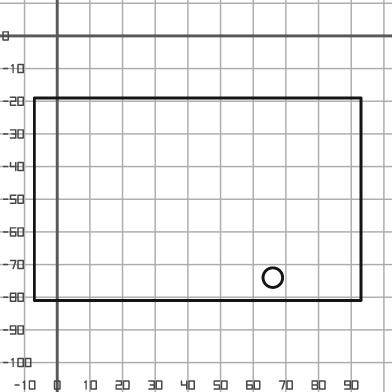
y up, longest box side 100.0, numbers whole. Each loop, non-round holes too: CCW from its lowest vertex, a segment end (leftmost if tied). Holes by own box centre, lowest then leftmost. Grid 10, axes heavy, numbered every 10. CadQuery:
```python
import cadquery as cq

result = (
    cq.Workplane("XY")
    .moveTo(-7.0, -81.0)
    .lineTo(93.0, -81.0)
    .lineTo(93.0, -19.0)
    .lineTo(-7.0, -19.0)
    .close()
    .moveTo(66.0, -74.0)
    .circle(3.0)
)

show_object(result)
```